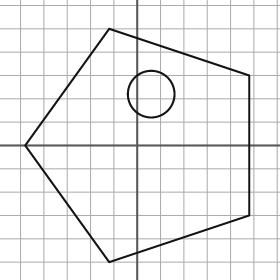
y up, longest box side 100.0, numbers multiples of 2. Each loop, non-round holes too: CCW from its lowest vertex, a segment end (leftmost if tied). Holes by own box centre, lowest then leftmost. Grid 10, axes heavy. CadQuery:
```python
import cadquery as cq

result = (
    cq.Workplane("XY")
    .moveTo(-12.0, -50.0)
    .lineTo(48.0, -30.0)
    .lineTo(48.0, 30.0)
    .lineTo(-12.0, 50.0)
    .lineTo(-48.0, 0.0)
    .close()
    .moveTo(6.0, 22.0)
    .circle(10.0)
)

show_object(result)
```